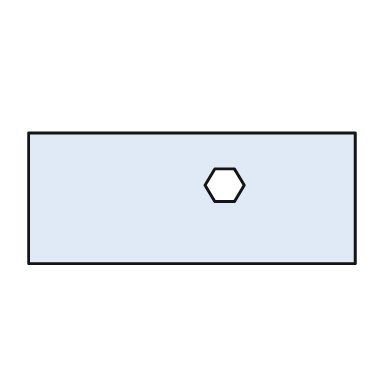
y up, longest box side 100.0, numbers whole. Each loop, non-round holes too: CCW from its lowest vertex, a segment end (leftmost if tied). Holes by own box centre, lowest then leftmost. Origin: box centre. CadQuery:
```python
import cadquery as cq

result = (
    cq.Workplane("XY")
    .moveTo(-50.0, -20.0)
    .lineTo(50.0, -20.0)
    .lineTo(50.0, 20.0)
    .lineTo(-50.0, 20.0)
    .close()
    .moveTo(7.0, -1.0)
    .lineTo(13.0, -1.0)
    .lineTo(16.0, 4.0)
    .lineTo(13.0, 9.0)
    .lineTo(7.0, 9.0)
    .lineTo(4.0, 4.0)
    .close()
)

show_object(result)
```